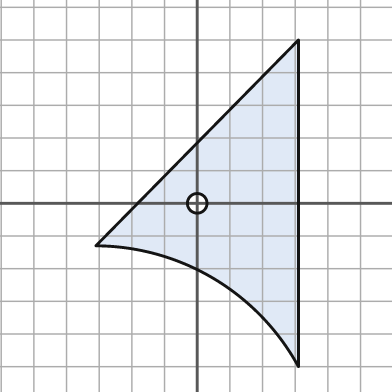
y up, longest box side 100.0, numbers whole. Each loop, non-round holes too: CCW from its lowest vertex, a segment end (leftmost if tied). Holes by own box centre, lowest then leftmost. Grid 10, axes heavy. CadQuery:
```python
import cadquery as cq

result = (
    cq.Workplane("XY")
    .moveTo(31.0, -50.0)
    .lineTo(31.0, 50.0)
    .lineTo(-31.0, -13.0)
    .threePointArc((5.0, -23.0), (31.0, -50.0))
    .close()
    .moveTo(0.0, 0.0)
    .circle(3.0)
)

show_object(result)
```